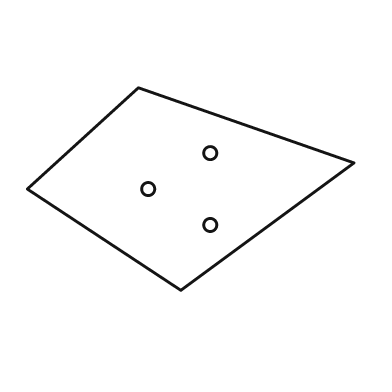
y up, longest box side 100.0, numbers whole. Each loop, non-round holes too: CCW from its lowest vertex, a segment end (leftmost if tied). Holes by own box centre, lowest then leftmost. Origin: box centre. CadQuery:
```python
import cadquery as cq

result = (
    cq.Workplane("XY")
    .moveTo(-3.0, -31.0)
    .lineTo(50.0, 8.0)
    .lineTo(-16.0, 31.0)
    .lineTo(-50.0, 0.0)
    .close()
    .moveTo(6.0, -11.0)
    .circle(2.0)
    .moveTo(-13.0, 0.0)
    .circle(2.0)
    .moveTo(6.0, 11.0)
    .circle(2.0)
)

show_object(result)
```